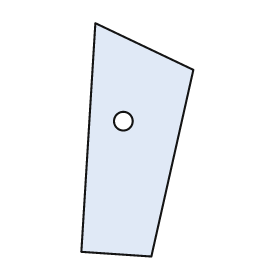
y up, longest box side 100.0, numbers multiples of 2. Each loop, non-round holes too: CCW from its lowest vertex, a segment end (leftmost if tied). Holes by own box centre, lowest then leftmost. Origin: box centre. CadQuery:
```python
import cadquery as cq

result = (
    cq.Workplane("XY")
    .moveTo(6.0, -50.0)
    .lineTo(24.0, 30.0)
    .lineTo(-18.0, 50.0)
    .lineTo(-24.0, -48.0)
    .close()
    .moveTo(-6.0, 8.0)
    .circle(4.0)
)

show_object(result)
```